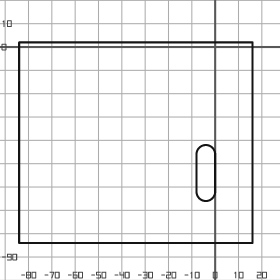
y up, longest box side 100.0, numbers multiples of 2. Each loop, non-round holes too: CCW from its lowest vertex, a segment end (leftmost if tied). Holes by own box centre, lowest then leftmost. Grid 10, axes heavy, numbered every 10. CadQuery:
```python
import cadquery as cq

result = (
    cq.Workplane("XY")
    .moveTo(-84.0, -84.0)
    .lineTo(16.0, -84.0)
    .lineTo(16.0, 2.0)
    .lineTo(-84.0, 2.0)
    .close()
    .moveTo(-8.0, -62.0)
    .threePointArc((-4.0, -66.0), (0.0, -62.0))
    .lineTo(0.0, -46.0)
    .threePointArc((-4.0, -42.0), (-8.0, -46.0))
    .close()
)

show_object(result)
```